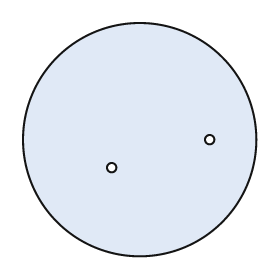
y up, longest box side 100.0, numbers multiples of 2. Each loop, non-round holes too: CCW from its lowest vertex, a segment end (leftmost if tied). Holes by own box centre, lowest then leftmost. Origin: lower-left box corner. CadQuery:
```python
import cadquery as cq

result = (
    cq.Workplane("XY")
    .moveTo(50.0, 50.0)
    .circle(50.0)
    .moveTo(38.0, 38.0)
    .circle(2.0)
    .moveTo(80.0, 50.0)
    .circle(2.0)
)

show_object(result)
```